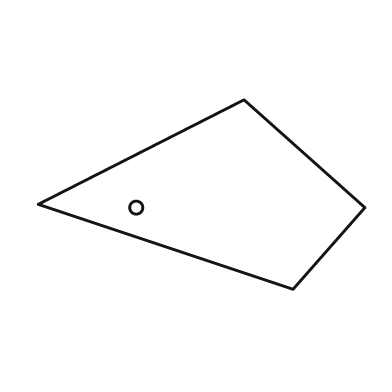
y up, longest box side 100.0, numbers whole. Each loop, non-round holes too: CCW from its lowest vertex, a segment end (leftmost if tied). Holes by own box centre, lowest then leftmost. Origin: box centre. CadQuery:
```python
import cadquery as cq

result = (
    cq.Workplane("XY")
    .moveTo(28.0, -29.0)
    .lineTo(50.0, -4.0)
    .lineTo(13.0, 29.0)
    .lineTo(-50.0, -3.0)
    .close()
    .moveTo(-20.0, -4.0)
    .circle(2.0)
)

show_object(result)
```